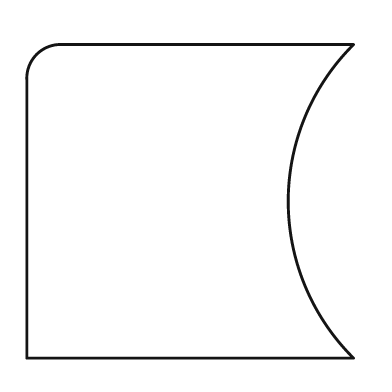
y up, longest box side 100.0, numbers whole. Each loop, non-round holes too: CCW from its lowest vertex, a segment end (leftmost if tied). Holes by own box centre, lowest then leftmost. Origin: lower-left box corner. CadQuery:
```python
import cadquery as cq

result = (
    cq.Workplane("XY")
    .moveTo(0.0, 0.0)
    .lineTo(100.0, 0.0)
    .threePointArc((80.0, 48.0), (100.0, 96.0))
    .lineTo(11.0, 96.0)
    .threePointArc((3.0, 93.0), (0.0, 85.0))
    .close()
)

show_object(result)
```